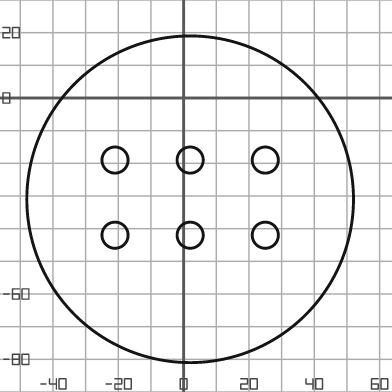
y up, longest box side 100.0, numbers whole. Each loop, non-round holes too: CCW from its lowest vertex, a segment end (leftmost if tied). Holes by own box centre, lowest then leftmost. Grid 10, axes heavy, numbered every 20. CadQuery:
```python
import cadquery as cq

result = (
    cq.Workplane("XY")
    .moveTo(2.0, -31.0)
    .circle(50.0)
    .moveTo(-21.0, -42.0)
    .circle(4.0)
    .moveTo(2.0, -42.0)
    .circle(4.0)
    .moveTo(25.0, -42.0)
    .circle(4.0)
    .moveTo(-21.0, -19.0)
    .circle(4.0)
    .moveTo(2.0, -19.0)
    .circle(4.0)
    .moveTo(25.0, -19.0)
    .circle(4.0)
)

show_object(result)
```